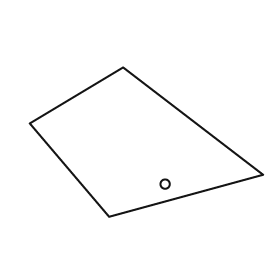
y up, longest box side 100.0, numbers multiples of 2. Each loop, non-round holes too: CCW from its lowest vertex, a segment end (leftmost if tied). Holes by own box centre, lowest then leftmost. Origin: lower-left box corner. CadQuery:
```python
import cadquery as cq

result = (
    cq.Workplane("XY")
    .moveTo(34.0, 0.0)
    .lineTo(100.0, 18.0)
    .lineTo(40.0, 64.0)
    .lineTo(0.0, 40.0)
    .close()
    .moveTo(58.0, 14.0)
    .circle(2.0)
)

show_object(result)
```